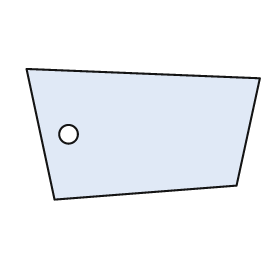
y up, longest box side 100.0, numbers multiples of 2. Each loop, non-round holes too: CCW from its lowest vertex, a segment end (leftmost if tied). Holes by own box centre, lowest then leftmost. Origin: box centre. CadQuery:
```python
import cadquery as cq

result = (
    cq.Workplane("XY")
    .moveTo(-38.0, -28.0)
    .lineTo(40.0, -22.0)
    .lineTo(50.0, 24.0)
    .lineTo(-50.0, 28.0)
    .close()
    .moveTo(-32.0, 0.0)
    .circle(4.0)
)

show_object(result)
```